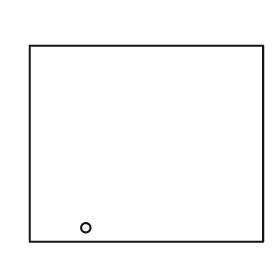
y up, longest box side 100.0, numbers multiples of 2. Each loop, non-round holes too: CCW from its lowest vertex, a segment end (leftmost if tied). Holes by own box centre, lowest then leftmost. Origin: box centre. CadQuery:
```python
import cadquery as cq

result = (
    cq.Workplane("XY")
    .moveTo(-50.0, -42.0)
    .lineTo(50.0, -42.0)
    .lineTo(50.0, 42.0)
    .lineTo(-50.0, 42.0)
    .close()
    .moveTo(-26.0, -36.0)
    .circle(2.0)
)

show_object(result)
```